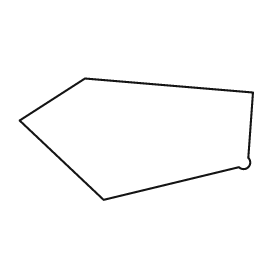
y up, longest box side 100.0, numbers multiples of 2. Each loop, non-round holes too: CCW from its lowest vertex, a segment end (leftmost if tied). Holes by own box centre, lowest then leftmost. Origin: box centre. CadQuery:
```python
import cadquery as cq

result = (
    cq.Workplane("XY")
    .moveTo(-14.0, -26.0)
    .lineTo(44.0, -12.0)
    .threePointArc((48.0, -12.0), (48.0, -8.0))
    .lineTo(50.0, 20.0)
    .lineTo(-22.0, 26.0)
    .lineTo(-50.0, 8.0)
    .close()
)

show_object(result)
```